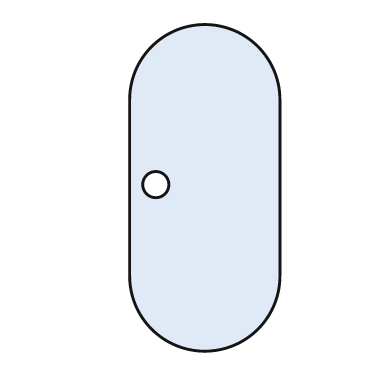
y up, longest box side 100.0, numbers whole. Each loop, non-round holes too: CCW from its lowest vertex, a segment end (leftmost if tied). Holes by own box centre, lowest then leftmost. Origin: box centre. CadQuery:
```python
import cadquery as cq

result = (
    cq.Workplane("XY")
    .moveTo(-23.0, -27.0)
    .threePointArc((0.0, -50.0), (23.0, -27.0))
    .lineTo(23.0, 27.0)
    .threePointArc((0.0, 50.0), (-23.0, 27.0))
    .close()
    .moveTo(-15.0, 1.0)
    .circle(4.0)
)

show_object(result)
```